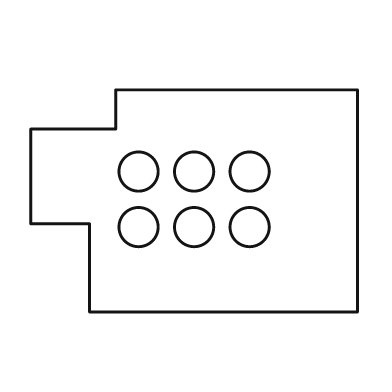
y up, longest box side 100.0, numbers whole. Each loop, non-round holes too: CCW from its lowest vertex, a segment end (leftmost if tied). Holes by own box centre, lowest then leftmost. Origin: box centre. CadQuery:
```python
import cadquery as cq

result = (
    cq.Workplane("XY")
    .moveTo(-32.0, -34.0)
    .lineTo(50.0, -34.0)
    .lineTo(50.0, 34.0)
    .lineTo(-24.0, 34.0)
    .lineTo(-24.0, 22.0)
    .lineTo(-50.0, 22.0)
    .lineTo(-50.0, -7.0)
    .lineTo(-32.0, -7.0)
    .close()
    .moveTo(-17.0, -8.0)
    .circle(6.0)
    .moveTo(0.0, -8.0)
    .circle(6.0)
    .moveTo(17.0, -8.0)
    .circle(6.0)
    .moveTo(-17.0, 9.0)
    .circle(6.0)
    .moveTo(0.0, 9.0)
    .circle(6.0)
    .moveTo(17.0, 9.0)
    .circle(6.0)
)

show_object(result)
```